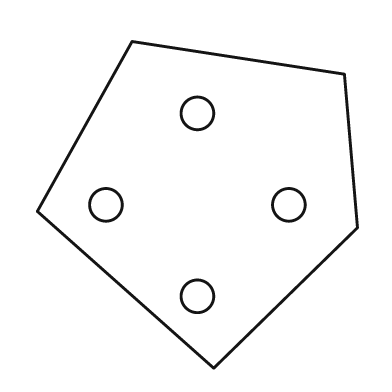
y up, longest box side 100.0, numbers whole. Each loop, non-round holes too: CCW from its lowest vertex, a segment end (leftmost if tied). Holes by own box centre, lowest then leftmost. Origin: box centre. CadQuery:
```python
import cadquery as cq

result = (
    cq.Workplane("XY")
    .moveTo(5.0, -50.0)
    .lineTo(49.0, -7.0)
    .lineTo(45.0, 40.0)
    .lineTo(-20.0, 50.0)
    .lineTo(-49.0, -2.0)
    .close()
    .moveTo(0.0, -28.0)
    .circle(5.0)
    .moveTo(-28.0, 0.0)
    .circle(5.0)
    .moveTo(28.0, 0.0)
    .circle(5.0)
    .moveTo(0.0, 28.0)
    .circle(5.0)
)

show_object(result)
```